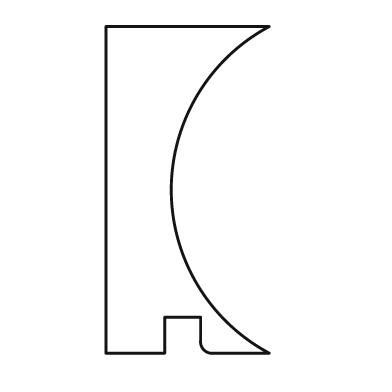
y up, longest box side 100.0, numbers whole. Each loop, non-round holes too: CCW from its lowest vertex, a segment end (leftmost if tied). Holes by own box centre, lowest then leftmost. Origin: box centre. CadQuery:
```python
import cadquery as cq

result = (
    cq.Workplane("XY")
    .moveTo(-25.0, -50.0)
    .lineTo(-7.0, -50.0)
    .lineTo(-7.0, -39.0)
    .lineTo(4.0, -39.0)
    .lineTo(4.0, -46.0)
    .threePointArc((5.0, -49.0), (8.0, -50.0))
    .lineTo(25.0, -50.0)
    .threePointArc((-5.0, 0.0), (25.0, 50.0))
    .lineTo(-25.0, 50.0)
    .close()
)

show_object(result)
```